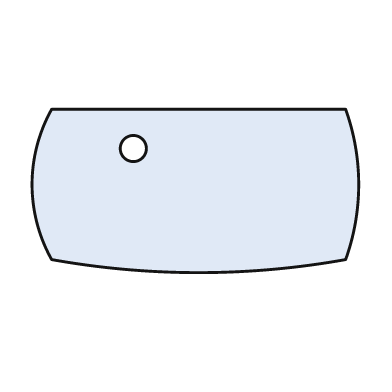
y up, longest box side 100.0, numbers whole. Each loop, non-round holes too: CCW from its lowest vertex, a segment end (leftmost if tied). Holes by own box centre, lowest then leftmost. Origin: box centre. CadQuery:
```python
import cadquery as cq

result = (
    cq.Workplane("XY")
    .moveTo(-44.0, -21.0)
    .threePointArc((1.0, -25.0), (46.0, -21.0))
    .threePointArc((50.0, 2.0), (46.0, 25.0))
    .lineTo(-44.0, 25.0)
    .threePointArc((-50.0, 2.0), (-44.0, -21.0))
    .close()
    .moveTo(-19.0, 13.0)
    .circle(4.0)
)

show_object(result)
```